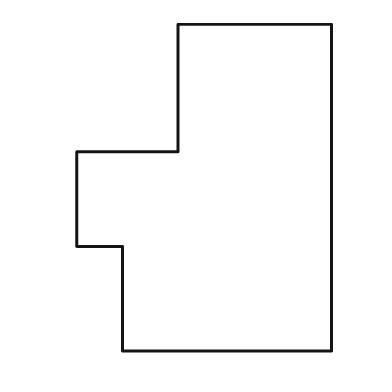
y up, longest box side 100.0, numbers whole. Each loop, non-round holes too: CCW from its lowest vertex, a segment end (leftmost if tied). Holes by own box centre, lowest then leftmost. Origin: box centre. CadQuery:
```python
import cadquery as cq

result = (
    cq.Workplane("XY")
    .moveTo(-25.0, -50.0)
    .lineTo(39.0, -50.0)
    .lineTo(39.0, 50.0)
    .lineTo(-8.0, 50.0)
    .lineTo(-8.0, 11.0)
    .lineTo(-39.0, 11.0)
    .lineTo(-39.0, -18.0)
    .lineTo(-25.0, -18.0)
    .close()
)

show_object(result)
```